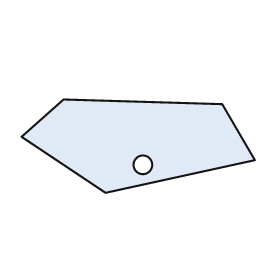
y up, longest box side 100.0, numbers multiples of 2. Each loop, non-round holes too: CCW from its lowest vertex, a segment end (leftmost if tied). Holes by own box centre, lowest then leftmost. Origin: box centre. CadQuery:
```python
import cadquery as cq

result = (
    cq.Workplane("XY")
    .moveTo(-14.0, -20.0)
    .lineTo(50.0, -6.0)
    .lineTo(36.0, 18.0)
    .lineTo(-32.0, 20.0)
    .lineTo(-50.0, 4.0)
    .close()
    .moveTo(2.0, -8.0)
    .circle(4.0)
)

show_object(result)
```